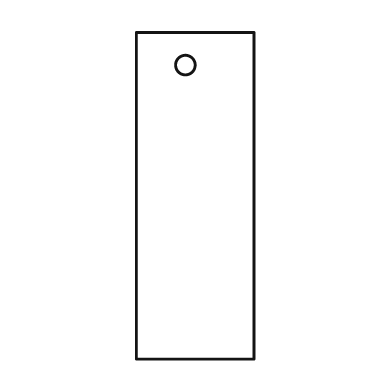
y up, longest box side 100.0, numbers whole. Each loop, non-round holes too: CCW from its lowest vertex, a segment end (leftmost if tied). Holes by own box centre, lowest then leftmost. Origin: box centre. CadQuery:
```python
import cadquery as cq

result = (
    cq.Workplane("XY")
    .moveTo(-18.0, -50.0)
    .lineTo(18.0, -50.0)
    .lineTo(18.0, 50.0)
    .lineTo(-18.0, 50.0)
    .close()
    .moveTo(-3.0, 40.0)
    .circle(3.0)
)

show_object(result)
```